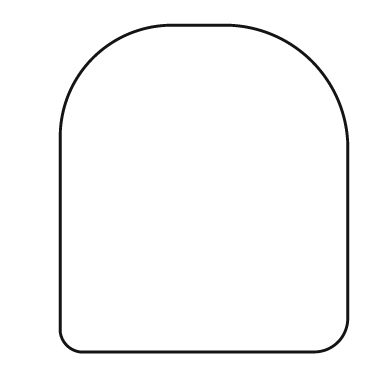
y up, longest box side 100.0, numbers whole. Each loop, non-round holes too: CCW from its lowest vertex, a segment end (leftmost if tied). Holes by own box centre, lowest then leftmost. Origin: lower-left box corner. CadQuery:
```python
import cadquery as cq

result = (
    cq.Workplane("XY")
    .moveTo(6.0, 0.0)
    .lineTo(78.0, 0.0)
    .threePointArc((85.0, 3.0), (88.0, 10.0))
    .lineTo(88.0, 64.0)
    .threePointArc((77.0, 89.0), (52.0, 100.0))
    .lineTo(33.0, 100.0)
    .threePointArc((10.0, 90.0), (0.0, 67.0))
    .lineTo(0.0, 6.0)
    .threePointArc((2.0, 2.0), (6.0, 0.0))
    .close()
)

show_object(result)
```